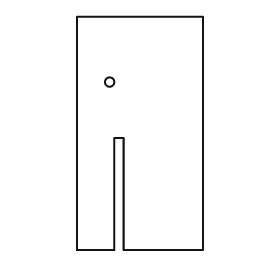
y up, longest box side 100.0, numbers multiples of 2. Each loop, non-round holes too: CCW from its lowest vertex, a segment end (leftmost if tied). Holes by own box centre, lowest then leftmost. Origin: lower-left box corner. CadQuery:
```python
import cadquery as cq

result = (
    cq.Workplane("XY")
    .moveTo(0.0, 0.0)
    .lineTo(16.0, 0.0)
    .lineTo(16.0, 48.0)
    .lineTo(20.0, 48.0)
    .lineTo(20.0, 0.0)
    .lineTo(54.0, 0.0)
    .lineTo(54.0, 100.0)
    .lineTo(0.0, 100.0)
    .close()
    .moveTo(14.0, 72.0)
    .circle(2.0)
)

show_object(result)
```